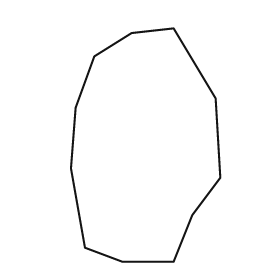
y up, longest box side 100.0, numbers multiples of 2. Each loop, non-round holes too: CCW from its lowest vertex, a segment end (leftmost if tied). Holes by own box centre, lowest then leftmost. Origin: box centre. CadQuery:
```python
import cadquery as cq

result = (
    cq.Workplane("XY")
    .moveTo(-10.0, -50.0)
    .lineTo(12.0, -50.0)
    .lineTo(20.0, -30.0)
    .lineTo(32.0, -14.0)
    .lineTo(30.0, 20.0)
    .lineTo(12.0, 50.0)
    .lineTo(-6.0, 48.0)
    .lineTo(-22.0, 38.0)
    .lineTo(-30.0, 16.0)
    .lineTo(-32.0, -10.0)
    .lineTo(-26.0, -44.0)
    .close()
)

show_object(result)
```